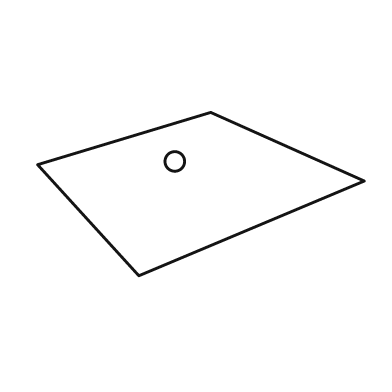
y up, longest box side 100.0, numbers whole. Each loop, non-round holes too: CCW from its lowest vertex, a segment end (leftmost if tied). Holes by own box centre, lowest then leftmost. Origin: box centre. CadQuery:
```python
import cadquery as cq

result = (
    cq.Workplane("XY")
    .moveTo(-19.0, -25.0)
    .lineTo(50.0, 4.0)
    .lineTo(3.0, 25.0)
    .lineTo(-50.0, 9.0)
    .close()
    .moveTo(-8.0, 10.0)
    .circle(3.0)
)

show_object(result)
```